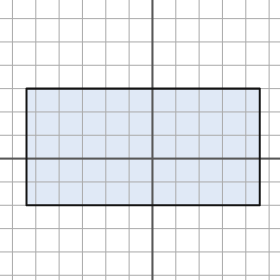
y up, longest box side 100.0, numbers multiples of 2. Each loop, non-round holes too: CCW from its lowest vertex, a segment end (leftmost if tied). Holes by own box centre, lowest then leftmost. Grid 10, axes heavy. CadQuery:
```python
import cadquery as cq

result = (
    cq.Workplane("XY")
    .moveTo(-54.0, -20.0)
    .lineTo(46.0, -20.0)
    .lineTo(46.0, 30.0)
    .lineTo(-54.0, 30.0)
    .close()
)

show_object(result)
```